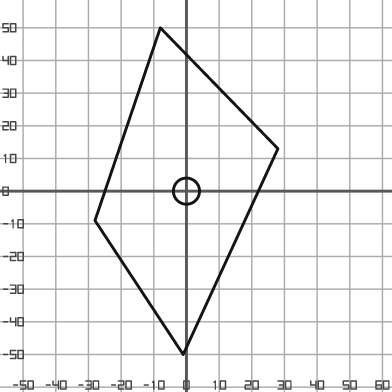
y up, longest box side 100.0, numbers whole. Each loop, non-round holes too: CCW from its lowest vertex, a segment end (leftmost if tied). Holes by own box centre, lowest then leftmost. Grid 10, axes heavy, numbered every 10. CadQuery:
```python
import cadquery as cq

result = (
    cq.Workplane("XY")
    .moveTo(-1.0, -50.0)
    .lineTo(28.0, 13.0)
    .lineTo(-8.0, 50.0)
    .lineTo(-28.0, -9.0)
    .close()
    .moveTo(0.0, 0.0)
    .circle(4.0)
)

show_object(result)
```